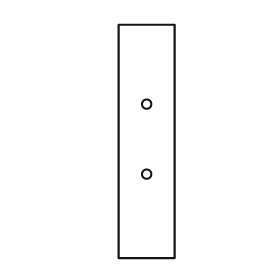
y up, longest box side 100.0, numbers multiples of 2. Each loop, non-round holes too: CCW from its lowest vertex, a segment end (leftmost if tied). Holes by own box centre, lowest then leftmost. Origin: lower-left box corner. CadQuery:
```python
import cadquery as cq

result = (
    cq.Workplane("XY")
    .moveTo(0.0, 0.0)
    .lineTo(24.0, 0.0)
    .lineTo(24.0, 100.0)
    .lineTo(0.0, 100.0)
    .close()
    .moveTo(12.0, 36.0)
    .circle(2.0)
    .moveTo(12.0, 66.0)
    .circle(2.0)
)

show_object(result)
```